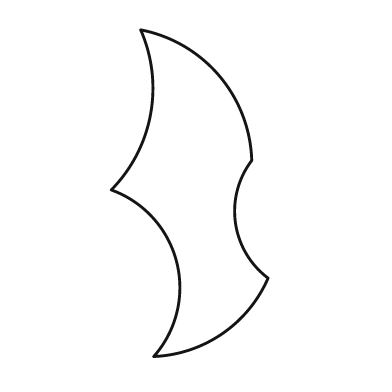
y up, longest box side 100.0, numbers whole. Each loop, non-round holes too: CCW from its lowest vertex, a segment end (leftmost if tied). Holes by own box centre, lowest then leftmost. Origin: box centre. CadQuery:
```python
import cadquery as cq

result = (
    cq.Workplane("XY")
    .moveTo(-11.0, -50.0)
    .threePointArc((10.0, -43.0), (24.0, -26.0))
    .threePointArc((14.0, -9.0), (19.0, 10.0))
    .threePointArc((9.0, 36.0), (-15.0, 50.0))
    .threePointArc((-12.0, 24.0), (-24.0, 1.0))
    .threePointArc((-4.0, -21.0), (-11.0, -50.0))
    .close()
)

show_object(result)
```